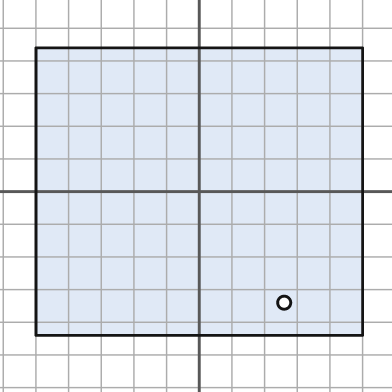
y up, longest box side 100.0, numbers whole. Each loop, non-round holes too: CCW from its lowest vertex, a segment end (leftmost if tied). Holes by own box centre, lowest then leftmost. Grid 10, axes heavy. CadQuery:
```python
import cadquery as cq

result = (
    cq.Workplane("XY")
    .moveTo(-50.0, -44.0)
    .lineTo(50.0, -44.0)
    .lineTo(50.0, 44.0)
    .lineTo(-50.0, 44.0)
    .close()
    .moveTo(26.0, -34.0)
    .circle(2.0)
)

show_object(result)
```